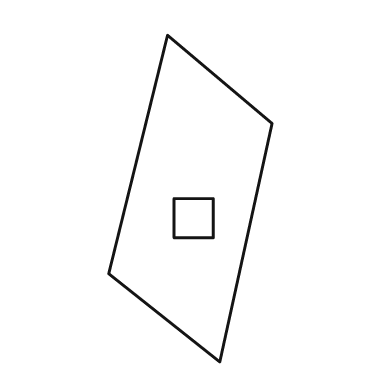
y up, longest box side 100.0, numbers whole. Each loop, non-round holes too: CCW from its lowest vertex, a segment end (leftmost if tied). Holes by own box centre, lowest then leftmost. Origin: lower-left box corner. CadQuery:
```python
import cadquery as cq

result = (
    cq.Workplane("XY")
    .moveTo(34.0, 0.0)
    .lineTo(50.0, 73.0)
    .lineTo(18.0, 100.0)
    .lineTo(0.0, 27.0)
    .close()
    .moveTo(20.0, 38.0)
    .lineTo(32.0, 38.0)
    .lineTo(32.0, 50.0)
    .lineTo(20.0, 50.0)
    .close()
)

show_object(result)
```